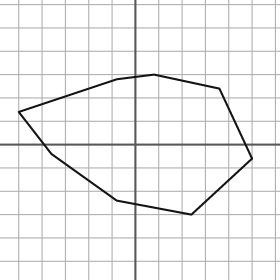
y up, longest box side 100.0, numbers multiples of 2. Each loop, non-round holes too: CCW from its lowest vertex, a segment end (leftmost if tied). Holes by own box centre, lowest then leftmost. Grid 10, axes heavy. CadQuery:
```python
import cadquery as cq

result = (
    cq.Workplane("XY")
    .moveTo(24.0, -30.0)
    .lineTo(50.0, -6.0)
    .lineTo(36.0, 24.0)
    .lineTo(8.0, 30.0)
    .lineTo(-8.0, 28.0)
    .lineTo(-50.0, 14.0)
    .lineTo(-36.0, -4.0)
    .lineTo(-8.0, -24.0)
    .close()
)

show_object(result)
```